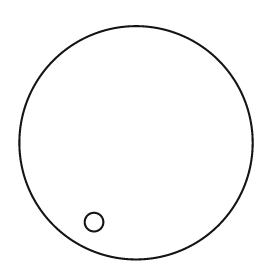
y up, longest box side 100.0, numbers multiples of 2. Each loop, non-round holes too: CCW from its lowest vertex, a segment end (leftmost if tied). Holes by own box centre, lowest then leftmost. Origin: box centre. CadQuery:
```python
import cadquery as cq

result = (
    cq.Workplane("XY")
    .moveTo(0.0, 0.0)
    .circle(50.0)
    .moveTo(-18.0, -34.0)
    .circle(4.0)
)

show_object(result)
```